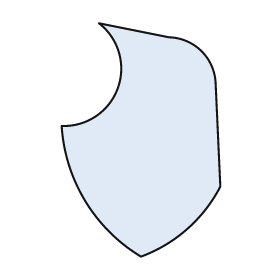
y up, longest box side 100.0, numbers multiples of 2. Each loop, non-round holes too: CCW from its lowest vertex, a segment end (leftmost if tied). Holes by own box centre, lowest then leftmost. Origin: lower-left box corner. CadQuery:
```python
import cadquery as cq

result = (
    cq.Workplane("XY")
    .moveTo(34.0, 0.0)
    .threePointArc((54.0, 12.0), (68.0, 30.0))
    .lineTo(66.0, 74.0)
    .threePointArc((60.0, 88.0), (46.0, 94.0))
    .lineTo(16.0, 100.0)
    .threePointArc((24.0, 72.0), (0.0, 56.0))
    .threePointArc((10.0, 24.0), (34.0, 0.0))
    .close()
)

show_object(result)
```